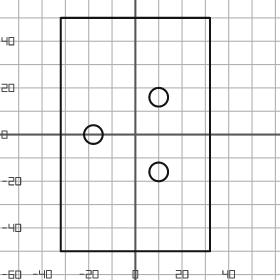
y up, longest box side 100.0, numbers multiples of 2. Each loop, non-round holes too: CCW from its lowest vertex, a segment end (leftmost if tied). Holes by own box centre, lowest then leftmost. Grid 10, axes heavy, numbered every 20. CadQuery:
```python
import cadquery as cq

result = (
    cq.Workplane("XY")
    .moveTo(-32.0, -50.0)
    .lineTo(32.0, -50.0)
    .lineTo(32.0, 50.0)
    .lineTo(-32.0, 50.0)
    .close()
    .moveTo(10.0, -16.0)
    .circle(4.0)
    .moveTo(-18.0, 0.0)
    .circle(4.0)
    .moveTo(10.0, 16.0)
    .circle(4.0)
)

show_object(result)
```